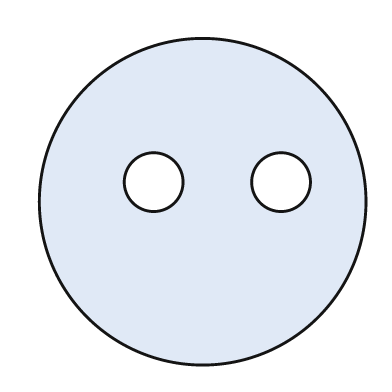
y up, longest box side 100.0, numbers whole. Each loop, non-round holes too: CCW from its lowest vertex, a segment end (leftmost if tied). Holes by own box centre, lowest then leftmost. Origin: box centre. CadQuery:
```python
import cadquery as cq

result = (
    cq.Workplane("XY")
    .moveTo(0.0, 0.0)
    .circle(50.0)
    .moveTo(-15.0, 6.0)
    .circle(9.0)
    .moveTo(24.0, 6.0)
    .circle(9.0)
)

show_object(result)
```